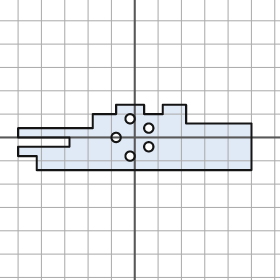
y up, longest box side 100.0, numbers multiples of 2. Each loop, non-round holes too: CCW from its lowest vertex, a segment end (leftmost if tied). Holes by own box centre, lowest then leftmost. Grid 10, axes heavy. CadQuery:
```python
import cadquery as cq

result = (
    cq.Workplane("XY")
    .moveTo(-42.0, -14.0)
    .lineTo(50.0, -14.0)
    .lineTo(50.0, 6.0)
    .lineTo(22.0, 6.0)
    .lineTo(22.0, 14.0)
    .lineTo(12.0, 14.0)
    .lineTo(12.0, 10.0)
    .lineTo(4.0, 10.0)
    .lineTo(4.0, 14.0)
    .lineTo(-8.0, 14.0)
    .lineTo(-8.0, 10.0)
    .lineTo(-18.0, 10.0)
    .lineTo(-18.0, 4.0)
    .lineTo(-50.0, 4.0)
    .lineTo(-50.0, 0.0)
    .lineTo(-28.0, 0.0)
    .lineTo(-28.0, -4.0)
    .lineTo(-50.0, -4.0)
    .lineTo(-50.0, -8.0)
    .lineTo(-42.0, -8.0)
    .close()
    .moveTo(-2.0, -8.0)
    .circle(2.0)
    .moveTo(6.0, -4.0)
    .circle(2.0)
    .moveTo(-8.0, 0.0)
    .circle(2.0)
    .moveTo(6.0, 4.0)
    .circle(2.0)
    .moveTo(-2.0, 8.0)
    .circle(2.0)
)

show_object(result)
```